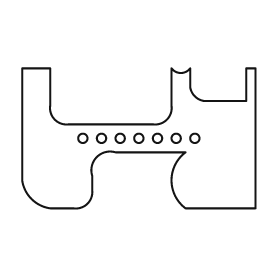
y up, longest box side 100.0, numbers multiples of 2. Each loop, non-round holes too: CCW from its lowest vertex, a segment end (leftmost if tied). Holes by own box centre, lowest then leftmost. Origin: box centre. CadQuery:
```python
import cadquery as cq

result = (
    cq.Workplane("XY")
    .moveTo(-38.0, -30.0)
    .lineTo(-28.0, -30.0)
    .threePointArc((-22.0, -28.0), (-20.0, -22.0))
    .lineTo(-20.0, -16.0)
    .threePointArc((-18.0, -8.0), (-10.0, -6.0))
    .lineTo(20.0, -6.0)
    .threePointArc((14.0, -18.0), (20.0, -30.0))
    .lineTo(50.0, -30.0)
    .lineTo(50.0, 30.0)
    .lineTo(46.0, 30.0)
    .lineTo(46.0, 16.0)
    .lineTo(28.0, 16.0)
    .threePointArc((24.0, 18.0), (22.0, 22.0))
    .lineTo(22.0, 30.0)
    .threePointArc((18.0, 28.0), (14.0, 30.0))
    .lineTo(14.0, 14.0)
    .threePointArc((12.0, 8.0), (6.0, 6.0))
    .lineTo(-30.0, 6.0)
    .threePointArc((-36.0, 8.0), (-38.0, 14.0))
    .lineTo(-38.0, 30.0)
    .lineTo(-50.0, 30.0)
    .lineTo(-50.0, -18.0)
    .threePointArc((-46.0, -26.0), (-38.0, -30.0))
    .close()
    .moveTo(-24.0, 0.0)
    .circle(2.0)
    .moveTo(-16.0, 0.0)
    .circle(2.0)
    .moveTo(-8.0, 0.0)
    .circle(2.0)
    .moveTo(0.0, 0.0)
    .circle(2.0)
    .moveTo(8.0, 0.0)
    .circle(2.0)
    .moveTo(16.0, 0.0)
    .circle(2.0)
    .moveTo(24.0, 0.0)
    .circle(2.0)
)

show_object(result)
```